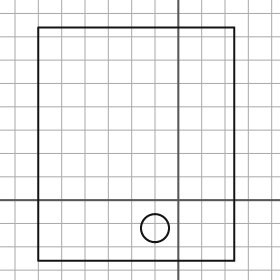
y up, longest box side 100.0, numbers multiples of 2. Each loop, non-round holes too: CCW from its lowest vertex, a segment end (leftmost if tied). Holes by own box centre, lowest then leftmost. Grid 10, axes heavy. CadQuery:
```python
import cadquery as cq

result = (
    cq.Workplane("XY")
    .moveTo(-60.0, -26.0)
    .lineTo(24.0, -26.0)
    .lineTo(24.0, 74.0)
    .lineTo(-60.0, 74.0)
    .close()
    .moveTo(-10.0, -12.0)
    .circle(6.0)
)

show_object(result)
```